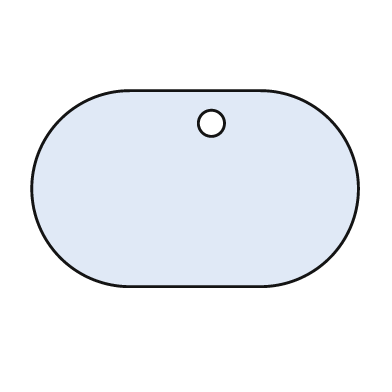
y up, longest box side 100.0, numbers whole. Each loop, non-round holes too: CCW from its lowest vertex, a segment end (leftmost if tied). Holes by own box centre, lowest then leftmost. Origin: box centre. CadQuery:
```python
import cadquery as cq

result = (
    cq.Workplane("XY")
    .moveTo(-20.0, -30.0)
    .lineTo(20.0, -30.0)
    .threePointArc((50.0, 0.0), (20.0, 30.0))
    .lineTo(-20.0, 30.0)
    .threePointArc((-50.0, 0.0), (-20.0, -30.0))
    .close()
    .moveTo(5.0, 20.0)
    .circle(4.0)
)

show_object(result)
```